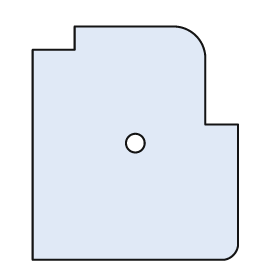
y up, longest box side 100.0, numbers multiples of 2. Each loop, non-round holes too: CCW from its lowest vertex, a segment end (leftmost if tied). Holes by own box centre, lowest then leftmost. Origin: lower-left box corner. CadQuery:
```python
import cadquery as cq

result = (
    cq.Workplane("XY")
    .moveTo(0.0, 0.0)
    .lineTo(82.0, 0.0)
    .threePointArc((86.0, 2.0), (88.0, 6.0))
    .lineTo(88.0, 58.0)
    .lineTo(74.0, 58.0)
    .lineTo(74.0, 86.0)
    .threePointArc((70.0, 96.0), (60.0, 100.0))
    .lineTo(18.0, 100.0)
    .lineTo(18.0, 90.0)
    .lineTo(0.0, 90.0)
    .close()
    .moveTo(44.0, 50.0)
    .circle(4.0)
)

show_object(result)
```